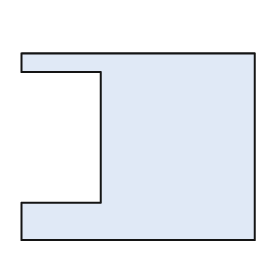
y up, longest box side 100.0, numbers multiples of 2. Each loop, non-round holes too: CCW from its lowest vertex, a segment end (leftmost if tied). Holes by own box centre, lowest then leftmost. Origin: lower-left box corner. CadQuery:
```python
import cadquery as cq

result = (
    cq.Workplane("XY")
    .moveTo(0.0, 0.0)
    .lineTo(100.0, 0.0)
    .lineTo(100.0, 80.0)
    .lineTo(0.0, 80.0)
    .lineTo(0.0, 72.0)
    .lineTo(34.0, 72.0)
    .lineTo(34.0, 16.0)
    .lineTo(0.0, 16.0)
    .close()
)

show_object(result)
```